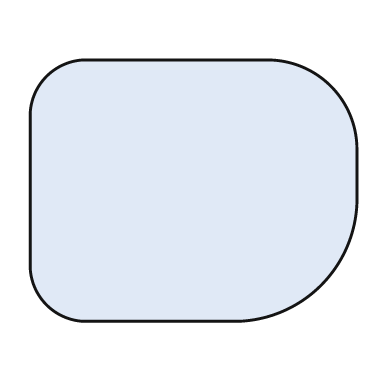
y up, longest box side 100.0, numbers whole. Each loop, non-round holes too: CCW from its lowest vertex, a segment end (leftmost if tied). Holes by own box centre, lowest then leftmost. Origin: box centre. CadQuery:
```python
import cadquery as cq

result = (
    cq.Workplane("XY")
    .moveTo(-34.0, -40.0)
    .lineTo(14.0, -40.0)
    .threePointArc((39.0, -29.0), (50.0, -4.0))
    .lineTo(50.0, 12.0)
    .threePointArc((42.0, 32.0), (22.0, 40.0))
    .lineTo(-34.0, 40.0)
    .threePointArc((-45.0, 35.0), (-50.0, 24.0))
    .lineTo(-50.0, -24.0)
    .threePointArc((-45.0, -35.0), (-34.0, -40.0))
    .close()
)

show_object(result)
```